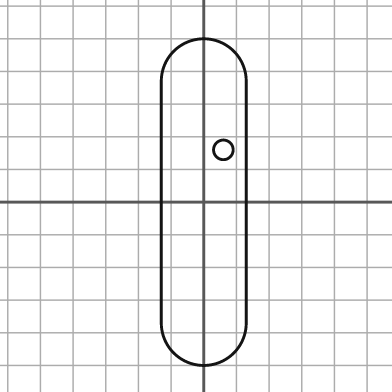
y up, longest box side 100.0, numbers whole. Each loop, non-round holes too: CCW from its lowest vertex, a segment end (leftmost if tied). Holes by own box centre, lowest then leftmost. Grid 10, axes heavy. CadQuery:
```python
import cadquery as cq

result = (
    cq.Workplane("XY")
    .moveTo(-13.0, -37.0)
    .threePointArc((0.0, -50.0), (13.0, -37.0))
    .lineTo(13.0, 37.0)
    .threePointArc((0.0, 50.0), (-13.0, 37.0))
    .close()
    .moveTo(6.0, 16.0)
    .circle(3.0)
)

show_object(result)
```